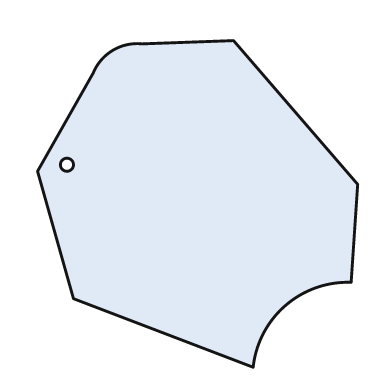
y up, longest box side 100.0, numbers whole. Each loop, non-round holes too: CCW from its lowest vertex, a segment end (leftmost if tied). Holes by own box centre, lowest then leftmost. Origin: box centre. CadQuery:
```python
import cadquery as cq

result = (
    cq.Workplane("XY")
    .moveTo(17.0, -50.0)
    .threePointArc((27.0, -31.0), (47.0, -24.0))
    .lineTo(49.0, 6.0)
    .lineTo(11.0, 50.0)
    .lineTo(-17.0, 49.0)
    .threePointArc((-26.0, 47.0), (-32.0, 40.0))
    .lineTo(-49.0, 10.0)
    .lineTo(-38.0, -29.0)
    .close()
    .moveTo(-40.0, 12.0)
    .circle(2.0)
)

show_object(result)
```